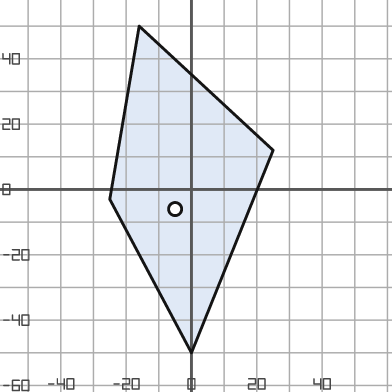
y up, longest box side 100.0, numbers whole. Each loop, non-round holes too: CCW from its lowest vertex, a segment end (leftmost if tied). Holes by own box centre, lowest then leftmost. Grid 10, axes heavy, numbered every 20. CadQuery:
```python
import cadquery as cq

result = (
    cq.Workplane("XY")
    .moveTo(0.0, -50.0)
    .lineTo(25.0, 12.0)
    .lineTo(-16.0, 50.0)
    .lineTo(-25.0, -3.0)
    .close()
    .moveTo(-5.0, -6.0)
    .circle(2.0)
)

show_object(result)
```